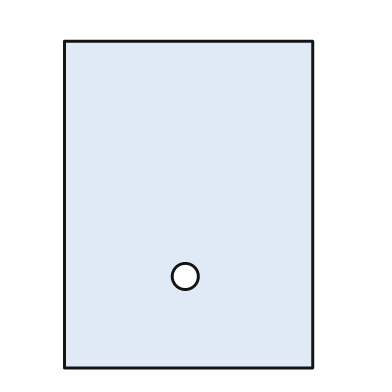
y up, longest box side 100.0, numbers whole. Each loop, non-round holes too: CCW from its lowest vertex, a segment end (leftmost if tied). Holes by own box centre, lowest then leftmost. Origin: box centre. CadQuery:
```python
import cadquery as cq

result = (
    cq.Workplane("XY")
    .moveTo(-38.0, -50.0)
    .lineTo(38.0, -50.0)
    .lineTo(38.0, 50.0)
    .lineTo(-38.0, 50.0)
    .close()
    .moveTo(-1.0, -22.0)
    .circle(4.0)
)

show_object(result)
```